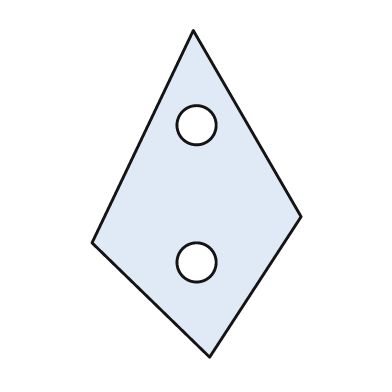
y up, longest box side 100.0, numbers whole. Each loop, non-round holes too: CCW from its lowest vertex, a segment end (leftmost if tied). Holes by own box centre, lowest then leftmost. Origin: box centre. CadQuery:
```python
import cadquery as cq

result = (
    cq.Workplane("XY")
    .moveTo(4.0, -50.0)
    .lineTo(32.0, -7.0)
    .lineTo(-1.0, 50.0)
    .lineTo(-32.0, -15.0)
    .close()
    .moveTo(0.0, -21.0)
    .circle(6.0)
    .moveTo(0.0, 21.0)
    .circle(6.0)
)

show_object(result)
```